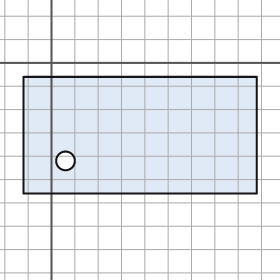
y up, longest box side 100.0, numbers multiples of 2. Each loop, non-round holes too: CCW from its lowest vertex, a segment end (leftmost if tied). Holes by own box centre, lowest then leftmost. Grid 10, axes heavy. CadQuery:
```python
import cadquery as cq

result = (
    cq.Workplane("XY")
    .moveTo(-12.0, -56.0)
    .lineTo(88.0, -56.0)
    .lineTo(88.0, -6.0)
    .lineTo(-12.0, -6.0)
    .close()
    .moveTo(6.0, -42.0)
    .circle(4.0)
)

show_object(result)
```